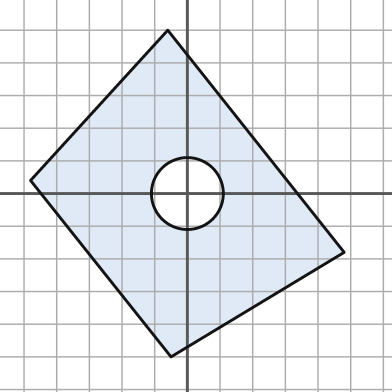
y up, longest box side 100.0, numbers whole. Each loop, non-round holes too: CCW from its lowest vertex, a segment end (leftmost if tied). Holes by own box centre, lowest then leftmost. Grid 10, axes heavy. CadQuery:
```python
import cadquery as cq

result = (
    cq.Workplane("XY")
    .moveTo(-5.0, -50.0)
    .lineTo(48.0, -18.0)
    .lineTo(-6.0, 50.0)
    .lineTo(-48.0, 4.0)
    .close()
    .moveTo(0.0, 0.0)
    .circle(11.0)
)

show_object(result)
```